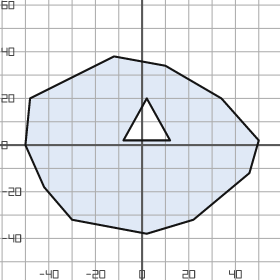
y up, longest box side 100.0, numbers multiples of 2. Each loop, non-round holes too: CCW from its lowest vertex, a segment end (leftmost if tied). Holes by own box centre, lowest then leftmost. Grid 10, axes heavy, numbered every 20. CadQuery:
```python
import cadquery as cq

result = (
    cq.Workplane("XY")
    .moveTo(2.0, -38.0)
    .lineTo(22.0, -32.0)
    .lineTo(46.0, -12.0)
    .lineTo(50.0, 2.0)
    .lineTo(34.0, 20.0)
    .lineTo(10.0, 34.0)
    .lineTo(-12.0, 38.0)
    .lineTo(-48.0, 20.0)
    .lineTo(-50.0, 0.0)
    .lineTo(-42.0, -18.0)
    .lineTo(-30.0, -32.0)
    .close()
    .moveTo(-8.0, 2.0)
    .lineTo(12.0, 2.0)
    .lineTo(2.0, 20.0)
    .close()
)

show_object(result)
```